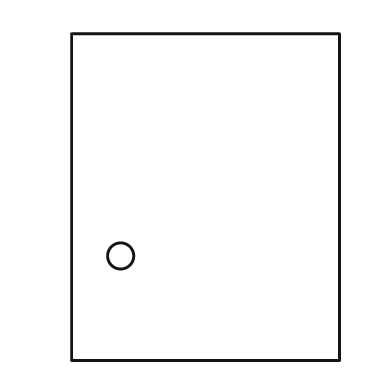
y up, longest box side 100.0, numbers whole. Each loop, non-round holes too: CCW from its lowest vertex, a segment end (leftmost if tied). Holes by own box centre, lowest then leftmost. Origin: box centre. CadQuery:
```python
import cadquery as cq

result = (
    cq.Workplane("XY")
    .moveTo(-41.0, -50.0)
    .lineTo(41.0, -50.0)
    .lineTo(41.0, 50.0)
    .lineTo(-41.0, 50.0)
    .close()
    .moveTo(-26.0, -18.0)
    .circle(4.0)
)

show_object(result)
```